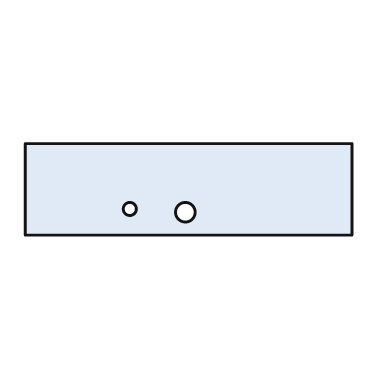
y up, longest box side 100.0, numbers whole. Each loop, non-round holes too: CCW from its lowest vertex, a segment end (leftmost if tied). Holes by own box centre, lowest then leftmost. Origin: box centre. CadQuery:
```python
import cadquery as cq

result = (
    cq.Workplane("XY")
    .moveTo(-50.0, -14.0)
    .lineTo(50.0, -14.0)
    .lineTo(50.0, 14.0)
    .lineTo(-50.0, 14.0)
    .close()
    .moveTo(-1.0, -7.0)
    .circle(3.0)
    .moveTo(-18.0, -6.0)
    .circle(2.0)
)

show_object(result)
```